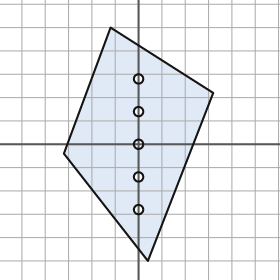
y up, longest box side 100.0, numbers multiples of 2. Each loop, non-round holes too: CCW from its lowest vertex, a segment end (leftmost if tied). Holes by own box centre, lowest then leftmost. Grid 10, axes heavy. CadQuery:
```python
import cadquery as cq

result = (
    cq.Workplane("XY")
    .moveTo(4.0, -50.0)
    .lineTo(32.0, 22.0)
    .lineTo(-12.0, 50.0)
    .lineTo(-32.0, -4.0)
    .close()
    .moveTo(0.0, -28.0)
    .circle(2.0)
    .moveTo(0.0, -14.0)
    .circle(2.0)
    .moveTo(0.0, 0.0)
    .circle(2.0)
    .moveTo(0.0, 14.0)
    .circle(2.0)
    .moveTo(0.0, 28.0)
    .circle(2.0)
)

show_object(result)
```